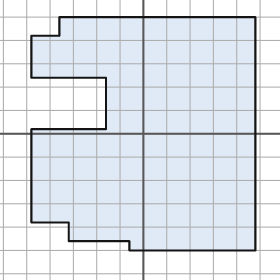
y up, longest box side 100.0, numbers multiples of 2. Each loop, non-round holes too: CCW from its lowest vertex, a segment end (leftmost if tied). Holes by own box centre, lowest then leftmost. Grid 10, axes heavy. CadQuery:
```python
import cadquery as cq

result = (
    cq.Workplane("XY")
    .moveTo(-6.0, -50.0)
    .lineTo(48.0, -50.0)
    .lineTo(48.0, 50.0)
    .lineTo(-36.0, 50.0)
    .lineTo(-36.0, 42.0)
    .lineTo(-48.0, 42.0)
    .lineTo(-48.0, 24.0)
    .lineTo(-16.0, 24.0)
    .lineTo(-16.0, 2.0)
    .lineTo(-48.0, 2.0)
    .lineTo(-48.0, -38.0)
    .lineTo(-32.0, -38.0)
    .lineTo(-32.0, -46.0)
    .lineTo(-6.0, -46.0)
    .close()
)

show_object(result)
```